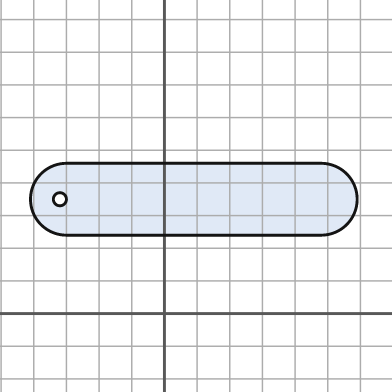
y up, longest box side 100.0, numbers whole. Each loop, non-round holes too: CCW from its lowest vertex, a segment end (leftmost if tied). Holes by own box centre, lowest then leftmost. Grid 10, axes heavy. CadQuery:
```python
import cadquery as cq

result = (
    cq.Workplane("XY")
    .moveTo(-30.0, 24.0)
    .lineTo(48.0, 24.0)
    .threePointArc((59.0, 35.0), (48.0, 46.0))
    .lineTo(-30.0, 46.0)
    .threePointArc((-41.0, 35.0), (-30.0, 24.0))
    .close()
    .moveTo(-32.0, 35.0)
    .circle(2.0)
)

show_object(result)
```